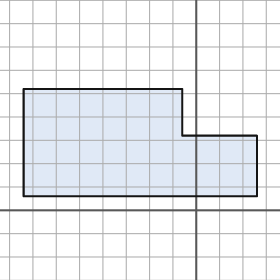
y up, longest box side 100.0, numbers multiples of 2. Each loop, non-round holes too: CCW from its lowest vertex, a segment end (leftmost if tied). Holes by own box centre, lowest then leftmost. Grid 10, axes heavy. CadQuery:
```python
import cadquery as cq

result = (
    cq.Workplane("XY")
    .moveTo(-74.0, 6.0)
    .lineTo(26.0, 6.0)
    .lineTo(26.0, 32.0)
    .lineTo(-6.0, 32.0)
    .lineTo(-6.0, 52.0)
    .lineTo(-74.0, 52.0)
    .close()
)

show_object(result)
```